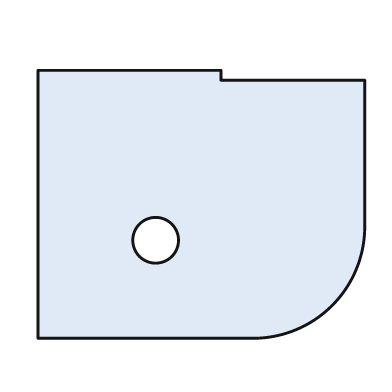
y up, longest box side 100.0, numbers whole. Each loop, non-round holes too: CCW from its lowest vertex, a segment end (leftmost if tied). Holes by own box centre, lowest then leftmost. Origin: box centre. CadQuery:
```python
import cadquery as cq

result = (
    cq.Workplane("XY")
    .moveTo(-50.0, -41.0)
    .lineTo(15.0, -41.0)
    .threePointArc((40.0, -31.0), (50.0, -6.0))
    .lineTo(50.0, 38.0)
    .lineTo(6.0, 38.0)
    .lineTo(6.0, 41.0)
    .lineTo(-50.0, 41.0)
    .close()
    .moveTo(-14.0, -11.0)
    .circle(7.0)
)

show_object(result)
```